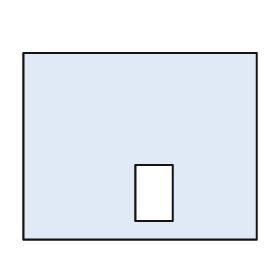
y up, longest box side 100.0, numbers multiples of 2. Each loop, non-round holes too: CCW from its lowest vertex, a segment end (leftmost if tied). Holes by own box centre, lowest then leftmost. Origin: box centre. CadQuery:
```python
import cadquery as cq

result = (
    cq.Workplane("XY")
    .moveTo(-50.0, -40.0)
    .lineTo(50.0, -40.0)
    .lineTo(50.0, 40.0)
    .lineTo(-50.0, 40.0)
    .close()
    .moveTo(-2.0, -32.0)
    .lineTo(14.0, -32.0)
    .lineTo(14.0, -8.0)
    .lineTo(-2.0, -8.0)
    .close()
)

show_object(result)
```